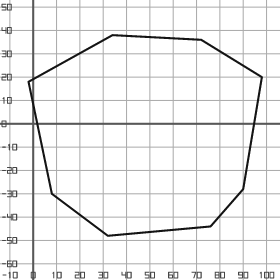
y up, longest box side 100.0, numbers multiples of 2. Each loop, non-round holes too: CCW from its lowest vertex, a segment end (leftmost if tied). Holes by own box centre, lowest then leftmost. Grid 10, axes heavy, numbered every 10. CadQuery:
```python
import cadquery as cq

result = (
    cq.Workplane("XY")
    .moveTo(32.0, -48.0)
    .lineTo(76.0, -44.0)
    .lineTo(90.0, -28.0)
    .lineTo(98.0, 20.0)
    .lineTo(72.0, 36.0)
    .lineTo(34.0, 38.0)
    .lineTo(-2.0, 18.0)
    .lineTo(8.0, -30.0)
    .close()
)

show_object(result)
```